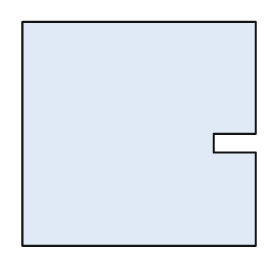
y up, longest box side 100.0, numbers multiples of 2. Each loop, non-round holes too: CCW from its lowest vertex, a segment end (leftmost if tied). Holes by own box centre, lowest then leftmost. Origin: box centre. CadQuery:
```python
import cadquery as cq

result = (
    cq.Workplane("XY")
    .moveTo(-50.0, -48.0)
    .lineTo(50.0, -48.0)
    .lineTo(50.0, -8.0)
    .lineTo(32.0, -8.0)
    .lineTo(32.0, 0.0)
    .lineTo(50.0, 0.0)
    .lineTo(50.0, 48.0)
    .lineTo(-50.0, 48.0)
    .close()
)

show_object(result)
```